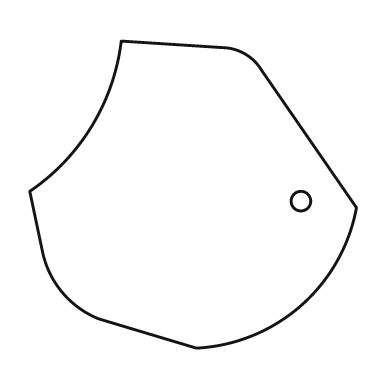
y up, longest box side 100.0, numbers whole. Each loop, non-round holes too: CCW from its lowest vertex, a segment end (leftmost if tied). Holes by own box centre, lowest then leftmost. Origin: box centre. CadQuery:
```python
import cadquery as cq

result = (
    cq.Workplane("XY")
    .moveTo(1.0, -47.0)
    .threePointArc((33.0, -34.0), (50.0, -4.0))
    .lineTo(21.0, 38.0)
    .threePointArc((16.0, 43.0), (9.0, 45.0))
    .lineTo(-22.0, 47.0)
    .threePointArc((-31.0, 21.0), (-50.0, 1.0))
    .lineTo(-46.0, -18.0)
    .threePointArc((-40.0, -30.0), (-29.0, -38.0))
    .close()
    .moveTo(33.0, -2.0)
    .circle(3.0)
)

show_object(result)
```